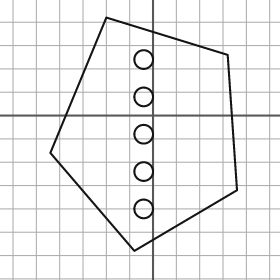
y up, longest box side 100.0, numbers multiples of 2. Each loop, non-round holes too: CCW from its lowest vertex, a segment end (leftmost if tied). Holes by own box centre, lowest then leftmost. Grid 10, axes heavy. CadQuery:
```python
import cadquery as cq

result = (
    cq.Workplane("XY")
    .moveTo(-8.0, -58.0)
    .lineTo(36.0, -32.0)
    .lineTo(32.0, 26.0)
    .lineTo(-20.0, 42.0)
    .lineTo(-44.0, -16.0)
    .close()
    .moveTo(-4.0, -40.0)
    .circle(4.0)
    .moveTo(-4.0, -24.0)
    .circle(4.0)
    .moveTo(-4.0, -8.0)
    .circle(4.0)
    .moveTo(-4.0, 8.0)
    .circle(4.0)
    .moveTo(-4.0, 24.0)
    .circle(4.0)
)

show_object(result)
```